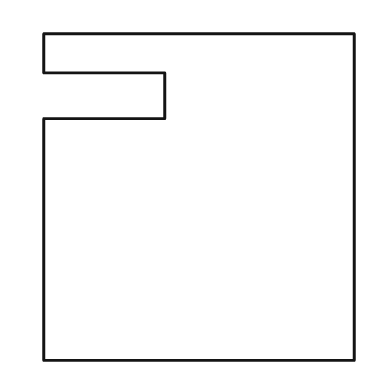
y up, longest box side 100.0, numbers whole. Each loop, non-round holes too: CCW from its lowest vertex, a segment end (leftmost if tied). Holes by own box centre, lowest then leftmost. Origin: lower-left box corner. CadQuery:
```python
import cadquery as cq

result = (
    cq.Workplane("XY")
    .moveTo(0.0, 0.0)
    .lineTo(95.0, 0.0)
    .lineTo(95.0, 100.0)
    .lineTo(0.0, 100.0)
    .lineTo(0.0, 88.0)
    .lineTo(37.0, 88.0)
    .lineTo(37.0, 74.0)
    .lineTo(0.0, 74.0)
    .close()
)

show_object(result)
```